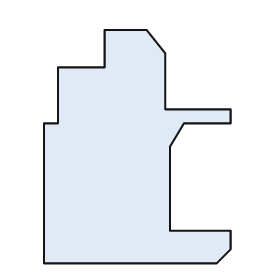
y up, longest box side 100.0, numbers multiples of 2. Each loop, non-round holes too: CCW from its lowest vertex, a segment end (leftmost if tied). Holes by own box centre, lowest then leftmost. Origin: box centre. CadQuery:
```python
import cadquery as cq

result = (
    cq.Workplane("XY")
    .moveTo(-40.0, -50.0)
    .lineTo(34.0, -50.0)
    .lineTo(40.0, -44.0)
    .lineTo(40.0, -36.0)
    .lineTo(14.0, -36.0)
    .lineTo(14.0, 0.0)
    .lineTo(20.0, 10.0)
    .lineTo(40.0, 10.0)
    .lineTo(40.0, 16.0)
    .lineTo(12.0, 16.0)
    .lineTo(12.0, 40.0)
    .lineTo(4.0, 50.0)
    .lineTo(-14.0, 50.0)
    .lineTo(-14.0, 34.0)
    .lineTo(-34.0, 34.0)
    .lineTo(-34.0, 10.0)
    .lineTo(-40.0, 10.0)
    .close()
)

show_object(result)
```